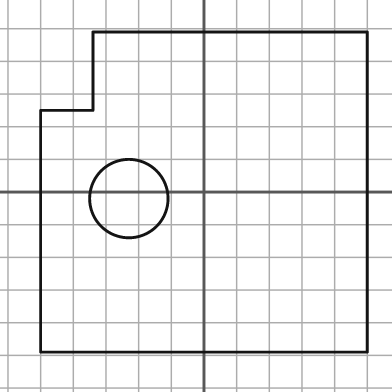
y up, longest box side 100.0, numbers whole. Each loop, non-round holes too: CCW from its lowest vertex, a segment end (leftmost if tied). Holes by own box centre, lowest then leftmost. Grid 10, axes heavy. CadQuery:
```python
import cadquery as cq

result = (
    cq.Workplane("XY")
    .moveTo(-50.0, -49.0)
    .lineTo(50.0, -49.0)
    .lineTo(50.0, 49.0)
    .lineTo(-34.0, 49.0)
    .lineTo(-34.0, 25.0)
    .lineTo(-50.0, 25.0)
    .close()
    .moveTo(-23.0, -2.0)
    .circle(12.0)
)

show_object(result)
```